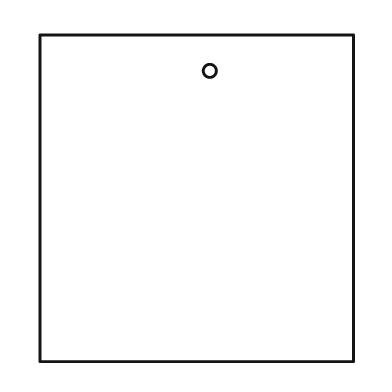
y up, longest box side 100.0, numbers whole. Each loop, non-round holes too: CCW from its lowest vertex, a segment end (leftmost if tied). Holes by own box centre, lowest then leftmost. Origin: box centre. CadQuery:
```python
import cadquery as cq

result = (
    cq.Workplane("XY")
    .moveTo(-48.0, -50.0)
    .lineTo(48.0, -50.0)
    .lineTo(48.0, 50.0)
    .lineTo(-48.0, 50.0)
    .close()
    .moveTo(4.0, 39.0)
    .circle(2.0)
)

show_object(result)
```